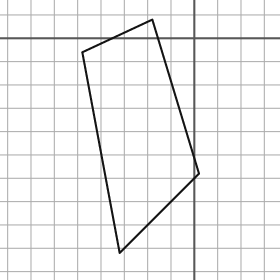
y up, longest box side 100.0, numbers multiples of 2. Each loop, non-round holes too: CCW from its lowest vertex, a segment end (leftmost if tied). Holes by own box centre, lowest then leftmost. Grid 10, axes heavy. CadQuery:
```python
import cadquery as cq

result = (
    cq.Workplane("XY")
    .moveTo(-32.0, -92.0)
    .lineTo(2.0, -58.0)
    .lineTo(-18.0, 8.0)
    .lineTo(-48.0, -6.0)
    .close()
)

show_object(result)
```